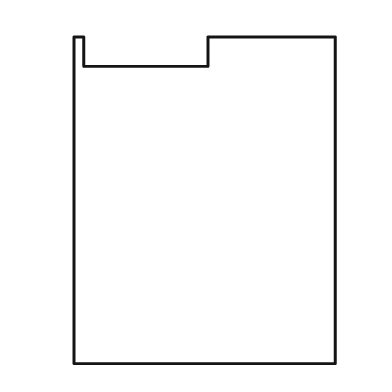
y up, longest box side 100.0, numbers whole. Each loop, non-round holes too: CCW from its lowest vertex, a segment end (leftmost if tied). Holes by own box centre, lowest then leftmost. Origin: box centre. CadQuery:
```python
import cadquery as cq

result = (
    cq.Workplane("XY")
    .moveTo(-40.0, -50.0)
    .lineTo(40.0, -50.0)
    .lineTo(40.0, 50.0)
    .lineTo(1.0, 50.0)
    .lineTo(1.0, 41.0)
    .lineTo(-37.0, 41.0)
    .lineTo(-37.0, 50.0)
    .lineTo(-40.0, 50.0)
    .close()
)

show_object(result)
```